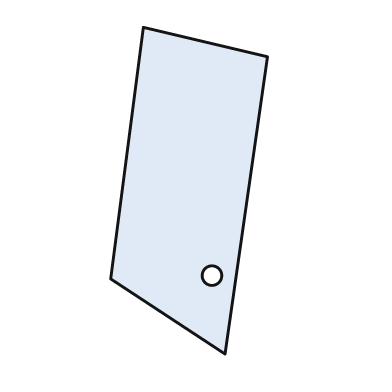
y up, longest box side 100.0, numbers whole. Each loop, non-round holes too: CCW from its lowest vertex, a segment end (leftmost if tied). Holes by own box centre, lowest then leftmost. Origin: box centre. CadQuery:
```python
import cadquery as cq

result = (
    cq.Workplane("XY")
    .moveTo(11.0, -50.0)
    .lineTo(24.0, 41.0)
    .lineTo(-14.0, 50.0)
    .lineTo(-24.0, -27.0)
    .close()
    .moveTo(7.0, -26.0)
    .circle(3.0)
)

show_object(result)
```